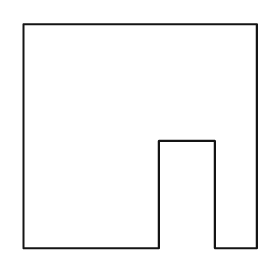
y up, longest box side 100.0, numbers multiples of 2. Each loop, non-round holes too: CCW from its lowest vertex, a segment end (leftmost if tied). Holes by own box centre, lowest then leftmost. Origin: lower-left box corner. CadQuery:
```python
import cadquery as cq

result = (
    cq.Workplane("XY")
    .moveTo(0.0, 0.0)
    .lineTo(58.0, 0.0)
    .lineTo(58.0, 46.0)
    .lineTo(82.0, 46.0)
    .lineTo(82.0, 0.0)
    .lineTo(100.0, 0.0)
    .lineTo(100.0, 96.0)
    .lineTo(0.0, 96.0)
    .close()
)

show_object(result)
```